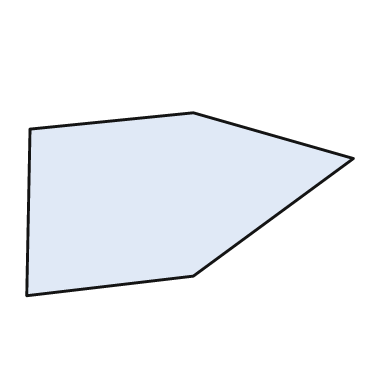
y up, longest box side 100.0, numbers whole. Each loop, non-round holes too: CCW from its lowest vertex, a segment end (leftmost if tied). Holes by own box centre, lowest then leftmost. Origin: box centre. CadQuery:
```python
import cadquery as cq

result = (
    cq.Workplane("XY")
    .moveTo(-50.0, -28.0)
    .lineTo(1.0, -22.0)
    .lineTo(50.0, 14.0)
    .lineTo(1.0, 28.0)
    .lineTo(-49.0, 23.0)
    .close()
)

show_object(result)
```